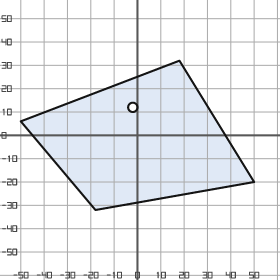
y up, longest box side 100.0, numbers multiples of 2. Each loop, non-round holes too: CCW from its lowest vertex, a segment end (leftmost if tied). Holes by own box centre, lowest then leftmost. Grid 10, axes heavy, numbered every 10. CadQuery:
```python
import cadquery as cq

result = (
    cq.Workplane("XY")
    .moveTo(-18.0, -32.0)
    .lineTo(50.0, -20.0)
    .lineTo(18.0, 32.0)
    .lineTo(-50.0, 6.0)
    .close()
    .moveTo(-2.0, 12.0)
    .circle(2.0)
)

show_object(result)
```